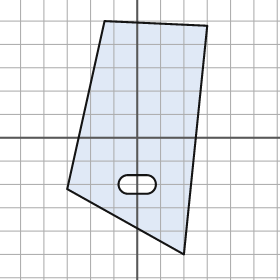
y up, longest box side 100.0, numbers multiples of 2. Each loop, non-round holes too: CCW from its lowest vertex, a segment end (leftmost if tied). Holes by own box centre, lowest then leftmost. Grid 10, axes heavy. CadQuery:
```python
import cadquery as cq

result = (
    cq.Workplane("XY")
    .moveTo(20.0, -50.0)
    .lineTo(30.0, 48.0)
    .lineTo(-14.0, 50.0)
    .lineTo(-30.0, -22.0)
    .close()
    .moveTo(-4.0, -24.0)
    .lineTo(4.0, -24.0)
    .threePointArc((8.0, -20.0), (4.0, -16.0))
    .lineTo(-4.0, -16.0)
    .threePointArc((-8.0, -20.0), (-4.0, -24.0))
    .close()
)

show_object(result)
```